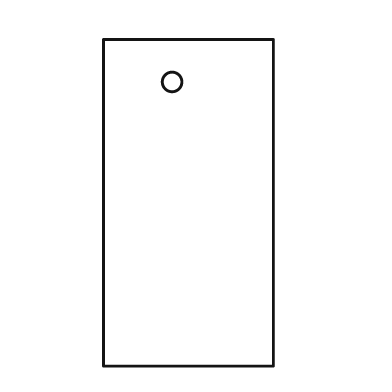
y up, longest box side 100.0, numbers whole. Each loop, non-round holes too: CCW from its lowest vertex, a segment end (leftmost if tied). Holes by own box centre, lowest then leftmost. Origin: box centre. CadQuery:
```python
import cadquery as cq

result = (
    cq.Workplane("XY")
    .moveTo(-26.0, -50.0)
    .lineTo(26.0, -50.0)
    .lineTo(26.0, 50.0)
    .lineTo(-26.0, 50.0)
    .close()
    .moveTo(-5.0, 37.0)
    .circle(3.0)
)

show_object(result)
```